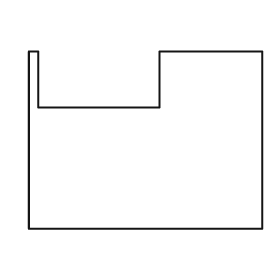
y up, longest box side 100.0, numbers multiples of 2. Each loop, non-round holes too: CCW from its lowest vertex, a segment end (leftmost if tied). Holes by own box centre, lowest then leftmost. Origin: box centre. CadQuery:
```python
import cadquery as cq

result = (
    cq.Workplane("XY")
    .moveTo(-50.0, -38.0)
    .lineTo(50.0, -38.0)
    .lineTo(50.0, 38.0)
    .lineTo(6.0, 38.0)
    .lineTo(6.0, 14.0)
    .lineTo(-46.0, 14.0)
    .lineTo(-46.0, 38.0)
    .lineTo(-50.0, 38.0)
    .close()
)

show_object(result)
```